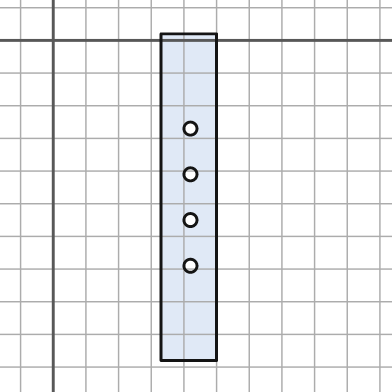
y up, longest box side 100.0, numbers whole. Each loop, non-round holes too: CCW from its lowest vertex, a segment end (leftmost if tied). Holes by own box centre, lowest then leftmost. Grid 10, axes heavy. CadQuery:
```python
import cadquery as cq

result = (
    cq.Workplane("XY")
    .moveTo(33.0, -98.0)
    .lineTo(50.0, -98.0)
    .lineTo(50.0, 2.0)
    .lineTo(33.0, 2.0)
    .close()
    .moveTo(42.0, -69.0)
    .circle(2.0)
    .moveTo(42.0, -55.0)
    .circle(2.0)
    .moveTo(42.0, -41.0)
    .circle(2.0)
    .moveTo(42.0, -27.0)
    .circle(2.0)
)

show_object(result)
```